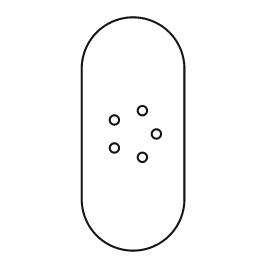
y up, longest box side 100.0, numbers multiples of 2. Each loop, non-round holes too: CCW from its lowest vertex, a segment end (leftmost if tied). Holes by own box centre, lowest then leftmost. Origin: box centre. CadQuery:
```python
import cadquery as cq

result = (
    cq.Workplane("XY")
    .moveTo(-22.0, -28.0)
    .threePointArc((0.0, -50.0), (22.0, -28.0))
    .lineTo(22.0, 28.0)
    .threePointArc((0.0, 50.0), (-22.0, 28.0))
    .close()
    .moveTo(4.0, -10.0)
    .circle(2.0)
    .moveTo(-8.0, -6.0)
    .circle(2.0)
    .moveTo(10.0, 0.0)
    .circle(2.0)
    .moveTo(-8.0, 6.0)
    .circle(2.0)
    .moveTo(4.0, 10.0)
    .circle(2.0)
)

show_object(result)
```